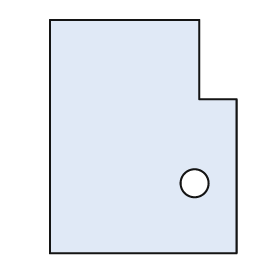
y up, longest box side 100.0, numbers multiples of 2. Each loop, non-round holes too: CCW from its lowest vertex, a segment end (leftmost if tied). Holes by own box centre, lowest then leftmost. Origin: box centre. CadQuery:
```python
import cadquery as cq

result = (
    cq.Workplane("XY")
    .moveTo(-40.0, -50.0)
    .lineTo(40.0, -50.0)
    .lineTo(40.0, 16.0)
    .lineTo(24.0, 16.0)
    .lineTo(24.0, 50.0)
    .lineTo(-40.0, 50.0)
    .close()
    .moveTo(22.0, -20.0)
    .circle(6.0)
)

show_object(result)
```